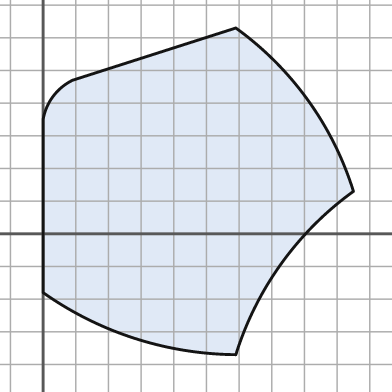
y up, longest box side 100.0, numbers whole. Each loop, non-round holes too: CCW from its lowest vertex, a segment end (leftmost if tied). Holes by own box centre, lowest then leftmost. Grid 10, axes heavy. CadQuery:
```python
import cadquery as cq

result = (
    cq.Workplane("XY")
    .moveTo(59.0, -37.0)
    .threePointArc((73.0, -9.0), (95.0, 13.0))
    .threePointArc((81.0, 41.0), (59.0, 63.0))
    .lineTo(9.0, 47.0)
    .threePointArc((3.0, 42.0), (0.0, 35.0))
    .lineTo(0.0, -18.0)
    .threePointArc((28.0, -32.0), (59.0, -37.0))
    .close()
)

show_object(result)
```